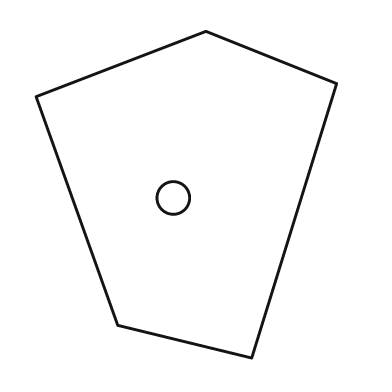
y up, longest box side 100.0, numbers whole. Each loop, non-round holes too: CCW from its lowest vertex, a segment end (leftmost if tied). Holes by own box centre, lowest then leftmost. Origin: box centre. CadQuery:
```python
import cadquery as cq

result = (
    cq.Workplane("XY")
    .moveTo(20.0, -50.0)
    .lineTo(46.0, 34.0)
    .lineTo(6.0, 50.0)
    .lineTo(-46.0, 30.0)
    .lineTo(-21.0, -40.0)
    .close()
    .moveTo(-4.0, -1.0)
    .circle(5.0)
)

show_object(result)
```